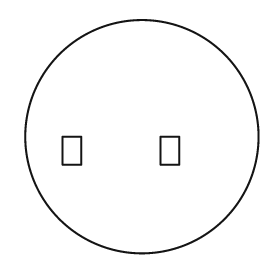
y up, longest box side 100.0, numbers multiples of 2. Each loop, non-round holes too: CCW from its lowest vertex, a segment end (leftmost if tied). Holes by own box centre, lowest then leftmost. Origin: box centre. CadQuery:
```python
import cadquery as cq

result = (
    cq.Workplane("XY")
    .moveTo(0.0, 0.0)
    .circle(50.0)
    .moveTo(-34.0, -12.0)
    .lineTo(-26.0, -12.0)
    .lineTo(-26.0, 0.0)
    .lineTo(-34.0, 0.0)
    .close()
    .moveTo(8.0, -12.0)
    .lineTo(16.0, -12.0)
    .lineTo(16.0, 0.0)
    .lineTo(8.0, 0.0)
    .close()
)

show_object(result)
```